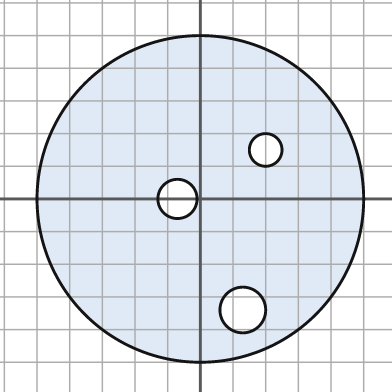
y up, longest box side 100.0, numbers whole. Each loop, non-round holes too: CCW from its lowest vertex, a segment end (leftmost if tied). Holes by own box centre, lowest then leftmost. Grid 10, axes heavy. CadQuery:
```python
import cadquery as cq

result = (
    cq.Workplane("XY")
    .moveTo(0.0, 0.0)
    .circle(50.0)
    .moveTo(13.0, -34.0)
    .circle(7.0)
    .moveTo(-7.0, 0.0)
    .circle(6.0)
    .moveTo(20.0, 15.0)
    .circle(5.0)
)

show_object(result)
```